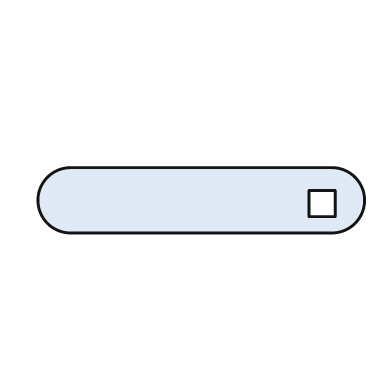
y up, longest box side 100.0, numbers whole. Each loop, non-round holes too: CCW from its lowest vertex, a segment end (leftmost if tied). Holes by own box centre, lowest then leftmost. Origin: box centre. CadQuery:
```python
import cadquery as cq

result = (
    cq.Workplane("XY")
    .moveTo(-40.0, -10.0)
    .lineTo(40.0, -10.0)
    .threePointArc((50.0, 0.0), (40.0, 10.0))
    .lineTo(-40.0, 10.0)
    .threePointArc((-50.0, 0.0), (-40.0, -10.0))
    .close()
    .moveTo(33.0, -5.0)
    .lineTo(41.0, -5.0)
    .lineTo(41.0, 3.0)
    .lineTo(33.0, 3.0)
    .close()
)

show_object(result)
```